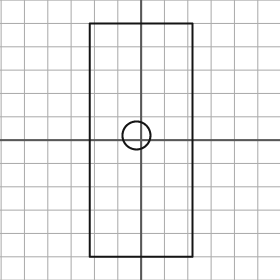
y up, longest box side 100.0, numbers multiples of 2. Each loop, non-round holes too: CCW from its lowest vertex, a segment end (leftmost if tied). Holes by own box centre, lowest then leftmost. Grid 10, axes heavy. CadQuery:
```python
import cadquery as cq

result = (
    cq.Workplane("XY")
    .moveTo(-22.0, -50.0)
    .lineTo(22.0, -50.0)
    .lineTo(22.0, 50.0)
    .lineTo(-22.0, 50.0)
    .close()
    .moveTo(-2.0, 2.0)
    .circle(6.0)
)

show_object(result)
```